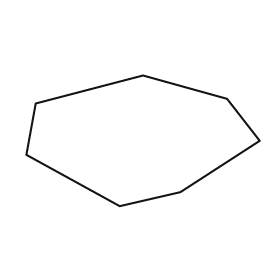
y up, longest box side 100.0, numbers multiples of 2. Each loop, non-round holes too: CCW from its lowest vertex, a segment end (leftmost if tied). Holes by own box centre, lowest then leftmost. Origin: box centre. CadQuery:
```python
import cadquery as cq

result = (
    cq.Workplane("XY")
    .moveTo(-10.0, -28.0)
    .lineTo(16.0, -22.0)
    .lineTo(50.0, 0.0)
    .lineTo(36.0, 18.0)
    .lineTo(0.0, 28.0)
    .lineTo(-46.0, 16.0)
    .lineTo(-50.0, -6.0)
    .close()
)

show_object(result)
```